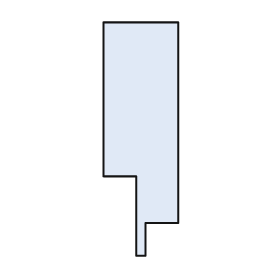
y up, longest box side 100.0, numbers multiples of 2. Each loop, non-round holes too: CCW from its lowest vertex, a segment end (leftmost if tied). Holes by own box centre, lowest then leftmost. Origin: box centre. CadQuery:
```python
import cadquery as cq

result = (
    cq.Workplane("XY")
    .moveTo(-2.0, -50.0)
    .lineTo(2.0, -50.0)
    .lineTo(2.0, -36.0)
    .lineTo(16.0, -36.0)
    .lineTo(16.0, 50.0)
    .lineTo(-16.0, 50.0)
    .lineTo(-16.0, -16.0)
    .lineTo(-2.0, -16.0)
    .close()
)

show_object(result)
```